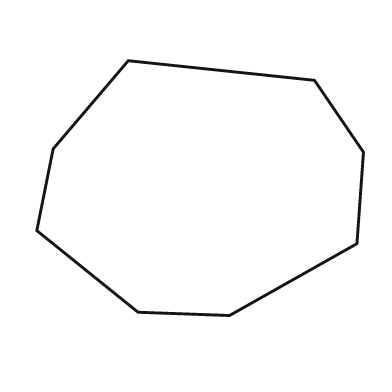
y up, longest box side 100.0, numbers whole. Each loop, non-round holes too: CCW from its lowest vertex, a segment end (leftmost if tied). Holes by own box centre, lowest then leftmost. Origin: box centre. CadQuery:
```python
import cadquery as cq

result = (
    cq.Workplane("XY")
    .moveTo(9.0, -39.0)
    .lineTo(48.0, -17.0)
    .lineTo(50.0, 11.0)
    .lineTo(35.0, 33.0)
    .lineTo(-22.0, 39.0)
    .lineTo(-45.0, 12.0)
    .lineTo(-50.0, -13.0)
    .lineTo(-19.0, -38.0)
    .close()
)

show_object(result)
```